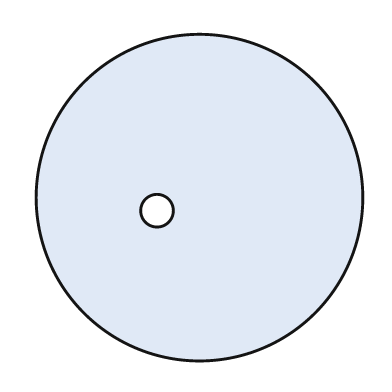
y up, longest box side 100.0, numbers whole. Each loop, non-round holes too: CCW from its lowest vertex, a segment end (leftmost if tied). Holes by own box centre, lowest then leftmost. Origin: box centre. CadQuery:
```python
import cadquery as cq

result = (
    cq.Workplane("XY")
    .moveTo(0.0, 0.0)
    .circle(50.0)
    .moveTo(-13.0, -4.0)
    .circle(5.0)
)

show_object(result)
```